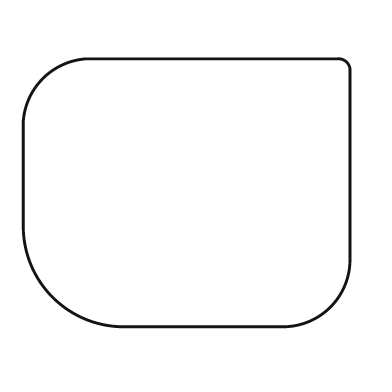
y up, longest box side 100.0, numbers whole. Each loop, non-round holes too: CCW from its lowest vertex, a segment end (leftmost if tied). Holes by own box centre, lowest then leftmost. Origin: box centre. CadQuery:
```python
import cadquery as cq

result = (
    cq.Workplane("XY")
    .moveTo(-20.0, -41.0)
    .lineTo(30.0, -41.0)
    .threePointArc((44.0, -35.0), (50.0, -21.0))
    .lineTo(50.0, 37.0)
    .threePointArc((49.0, 40.0), (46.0, 41.0))
    .lineTo(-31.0, 41.0)
    .threePointArc((-44.0, 35.0), (-50.0, 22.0))
    .lineTo(-50.0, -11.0)
    .threePointArc((-41.0, -32.0), (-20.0, -41.0))
    .close()
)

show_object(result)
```